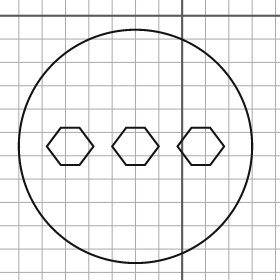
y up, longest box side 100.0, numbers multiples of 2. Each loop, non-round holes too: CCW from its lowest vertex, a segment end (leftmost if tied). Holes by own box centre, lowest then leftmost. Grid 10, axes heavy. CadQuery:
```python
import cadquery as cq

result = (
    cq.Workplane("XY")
    .moveTo(-20.0, -56.0)
    .circle(50.0)
    .moveTo(-52.0, -64.0)
    .lineTo(-44.0, -64.0)
    .lineTo(-38.0, -56.0)
    .lineTo(-44.0, -48.0)
    .lineTo(-52.0, -48.0)
    .lineTo(-58.0, -56.0)
    .close()
    .moveTo(-24.0, -64.0)
    .lineTo(-16.0, -64.0)
    .lineTo(-10.0, -56.0)
    .lineTo(-16.0, -48.0)
    .lineTo(-24.0, -48.0)
    .lineTo(-30.0, -56.0)
    .close()
    .moveTo(4.0, -64.0)
    .lineTo(12.0, -64.0)
    .lineTo(18.0, -56.0)
    .lineTo(12.0, -48.0)
    .lineTo(4.0, -48.0)
    .lineTo(-2.0, -56.0)
    .close()
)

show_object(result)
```